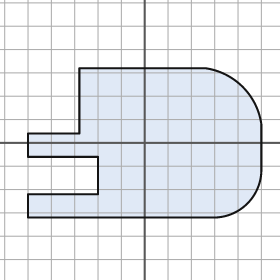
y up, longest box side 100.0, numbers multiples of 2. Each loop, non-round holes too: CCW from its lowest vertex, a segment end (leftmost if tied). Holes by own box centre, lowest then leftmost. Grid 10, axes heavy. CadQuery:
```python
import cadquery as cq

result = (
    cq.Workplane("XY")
    .moveTo(-50.0, -32.0)
    .lineTo(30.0, -32.0)
    .threePointArc((44.0, -26.0), (50.0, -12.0))
    .lineTo(50.0, 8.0)
    .threePointArc((42.0, 24.0), (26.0, 32.0))
    .lineTo(-28.0, 32.0)
    .lineTo(-28.0, 4.0)
    .lineTo(-50.0, 4.0)
    .lineTo(-50.0, -6.0)
    .lineTo(-20.0, -6.0)
    .lineTo(-20.0, -22.0)
    .lineTo(-50.0, -22.0)
    .close()
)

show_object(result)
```